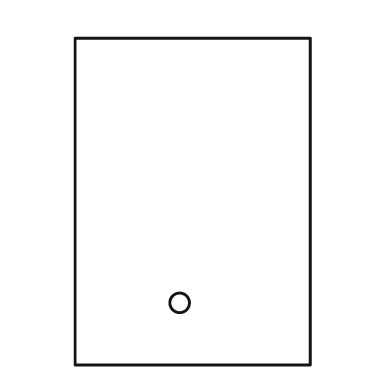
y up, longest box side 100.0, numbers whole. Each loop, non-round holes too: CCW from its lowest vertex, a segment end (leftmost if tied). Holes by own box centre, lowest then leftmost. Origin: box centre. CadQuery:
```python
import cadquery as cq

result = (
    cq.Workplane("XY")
    .moveTo(-36.0, -50.0)
    .lineTo(36.0, -50.0)
    .lineTo(36.0, 50.0)
    .lineTo(-36.0, 50.0)
    .close()
    .moveTo(-4.0, -31.0)
    .circle(3.0)
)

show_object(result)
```